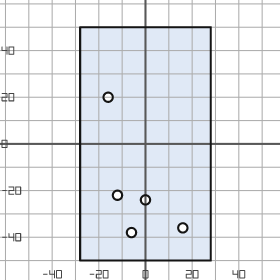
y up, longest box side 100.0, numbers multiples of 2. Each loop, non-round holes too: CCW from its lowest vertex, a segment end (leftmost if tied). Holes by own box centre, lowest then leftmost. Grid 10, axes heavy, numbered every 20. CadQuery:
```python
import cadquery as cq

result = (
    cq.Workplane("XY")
    .moveTo(-28.0, -50.0)
    .lineTo(28.0, -50.0)
    .lineTo(28.0, 50.0)
    .lineTo(-28.0, 50.0)
    .close()
    .moveTo(-6.0, -38.0)
    .circle(2.0)
    .moveTo(16.0, -36.0)
    .circle(2.0)
    .moveTo(0.0, -24.0)
    .circle(2.0)
    .moveTo(-12.0, -22.0)
    .circle(2.0)
    .moveTo(-16.0, 20.0)
    .circle(2.0)
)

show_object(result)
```